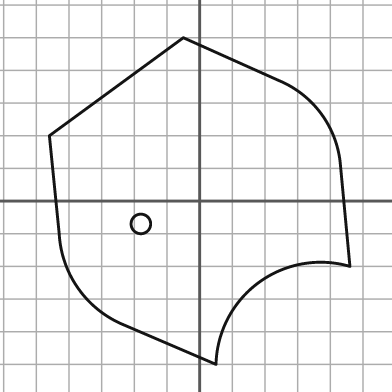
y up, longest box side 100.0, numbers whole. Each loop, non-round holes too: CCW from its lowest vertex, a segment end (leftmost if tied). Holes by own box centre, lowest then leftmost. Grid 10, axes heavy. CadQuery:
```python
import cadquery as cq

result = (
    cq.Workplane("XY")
    .moveTo(5.0, -50.0)
    .threePointArc((18.0, -25.0), (46.0, -20.0))
    .lineTo(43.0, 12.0)
    .threePointArc((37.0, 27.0), (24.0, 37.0))
    .lineTo(-5.0, 50.0)
    .lineTo(-46.0, 20.0)
    .lineTo(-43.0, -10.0)
    .threePointArc((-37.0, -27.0), (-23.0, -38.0))
    .close()
    .moveTo(-18.0, -7.0)
    .circle(3.0)
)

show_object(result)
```